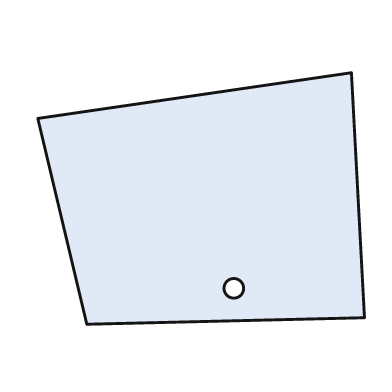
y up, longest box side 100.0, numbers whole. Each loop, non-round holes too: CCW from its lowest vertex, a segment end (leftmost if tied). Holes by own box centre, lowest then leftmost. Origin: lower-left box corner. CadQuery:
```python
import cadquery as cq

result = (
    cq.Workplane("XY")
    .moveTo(15.0, 0.0)
    .lineTo(100.0, 2.0)
    .lineTo(96.0, 77.0)
    .lineTo(0.0, 63.0)
    .close()
    .moveTo(60.0, 11.0)
    .circle(3.0)
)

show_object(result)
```